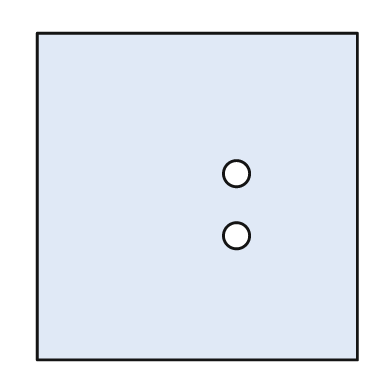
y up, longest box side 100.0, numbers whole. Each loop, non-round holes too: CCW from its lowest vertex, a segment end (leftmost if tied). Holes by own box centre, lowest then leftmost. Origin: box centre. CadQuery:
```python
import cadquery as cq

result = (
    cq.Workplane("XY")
    .moveTo(-49.0, -50.0)
    .lineTo(49.0, -50.0)
    .lineTo(49.0, 50.0)
    .lineTo(-49.0, 50.0)
    .close()
    .moveTo(12.0, -12.0)
    .circle(4.0)
    .moveTo(12.0, 7.0)
    .circle(4.0)
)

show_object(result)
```